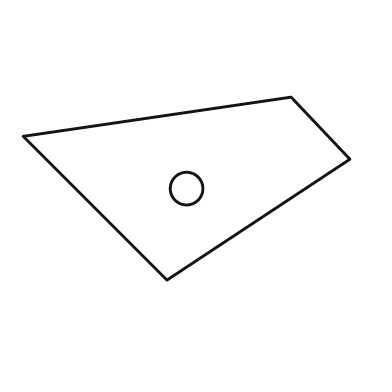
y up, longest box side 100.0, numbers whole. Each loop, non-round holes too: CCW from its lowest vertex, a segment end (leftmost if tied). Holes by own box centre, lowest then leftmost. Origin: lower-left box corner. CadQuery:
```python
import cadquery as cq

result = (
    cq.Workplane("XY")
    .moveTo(44.0, 0.0)
    .lineTo(100.0, 37.0)
    .lineTo(82.0, 56.0)
    .lineTo(0.0, 44.0)
    .close()
    .moveTo(50.0, 28.0)
    .circle(5.0)
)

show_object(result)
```